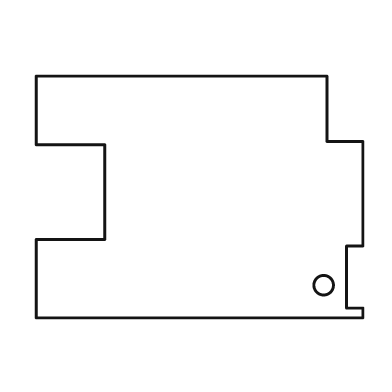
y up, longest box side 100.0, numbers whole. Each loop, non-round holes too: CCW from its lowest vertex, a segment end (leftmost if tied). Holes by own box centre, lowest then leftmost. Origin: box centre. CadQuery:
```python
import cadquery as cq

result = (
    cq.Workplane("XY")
    .moveTo(-50.0, -37.0)
    .lineTo(50.0, -37.0)
    .lineTo(50.0, -34.0)
    .lineTo(45.0, -34.0)
    .lineTo(45.0, -15.0)
    .lineTo(50.0, -15.0)
    .lineTo(50.0, 17.0)
    .lineTo(39.0, 17.0)
    .lineTo(39.0, 37.0)
    .lineTo(-50.0, 37.0)
    .lineTo(-50.0, 16.0)
    .lineTo(-29.0, 16.0)
    .lineTo(-29.0, -13.0)
    .lineTo(-50.0, -13.0)
    .close()
    .moveTo(38.0, -27.0)
    .circle(3.0)
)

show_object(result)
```